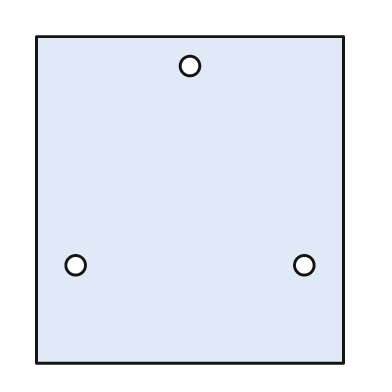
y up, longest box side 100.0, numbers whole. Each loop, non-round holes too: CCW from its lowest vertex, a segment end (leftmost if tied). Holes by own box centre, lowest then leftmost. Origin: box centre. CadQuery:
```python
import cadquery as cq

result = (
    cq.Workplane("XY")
    .moveTo(-47.0, -50.0)
    .lineTo(47.0, -50.0)
    .lineTo(47.0, 50.0)
    .lineTo(-47.0, 50.0)
    .close()
    .moveTo(-35.0, -20.0)
    .circle(3.0)
    .moveTo(35.0, -20.0)
    .circle(3.0)
    .moveTo(0.0, 41.0)
    .circle(3.0)
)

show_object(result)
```